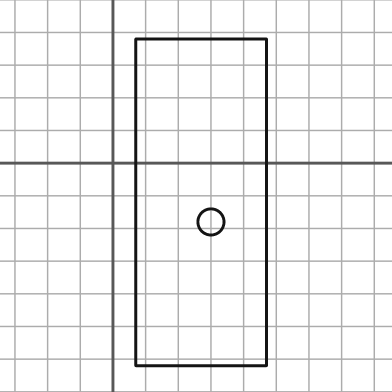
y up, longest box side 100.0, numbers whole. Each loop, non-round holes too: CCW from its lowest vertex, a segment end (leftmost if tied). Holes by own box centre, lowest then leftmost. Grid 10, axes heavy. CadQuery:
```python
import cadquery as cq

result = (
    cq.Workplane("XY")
    .moveTo(7.0, -62.0)
    .lineTo(47.0, -62.0)
    .lineTo(47.0, 38.0)
    .lineTo(7.0, 38.0)
    .close()
    .moveTo(30.0, -18.0)
    .circle(4.0)
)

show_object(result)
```